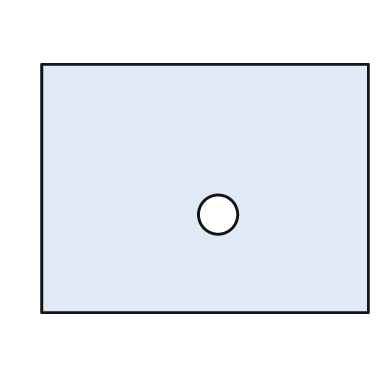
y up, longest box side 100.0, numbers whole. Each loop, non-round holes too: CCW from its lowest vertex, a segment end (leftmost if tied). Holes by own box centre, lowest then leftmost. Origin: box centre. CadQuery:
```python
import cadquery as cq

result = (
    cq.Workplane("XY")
    .moveTo(-50.0, -38.0)
    .lineTo(50.0, -38.0)
    .lineTo(50.0, 38.0)
    .lineTo(-50.0, 38.0)
    .close()
    .moveTo(4.0, -8.0)
    .circle(6.0)
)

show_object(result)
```